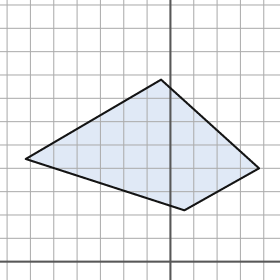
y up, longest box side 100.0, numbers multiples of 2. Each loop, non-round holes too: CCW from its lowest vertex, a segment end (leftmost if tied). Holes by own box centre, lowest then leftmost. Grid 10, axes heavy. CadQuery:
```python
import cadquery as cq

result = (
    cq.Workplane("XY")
    .moveTo(6.0, 22.0)
    .lineTo(38.0, 40.0)
    .lineTo(-4.0, 78.0)
    .lineTo(-62.0, 44.0)
    .close()
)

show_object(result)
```